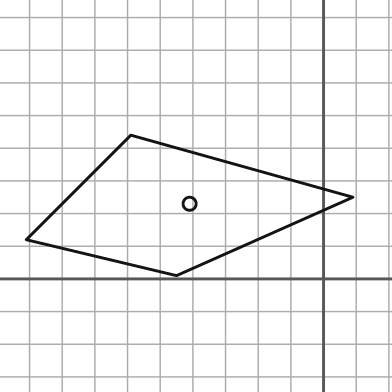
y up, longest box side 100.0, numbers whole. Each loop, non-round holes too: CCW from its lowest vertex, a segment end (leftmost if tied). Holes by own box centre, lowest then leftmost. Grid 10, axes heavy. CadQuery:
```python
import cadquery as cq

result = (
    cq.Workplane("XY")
    .moveTo(-45.0, 1.0)
    .lineTo(9.0, 25.0)
    .lineTo(-59.0, 44.0)
    .lineTo(-91.0, 12.0)
    .close()
    .moveTo(-41.0, 23.0)
    .circle(2.0)
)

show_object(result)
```